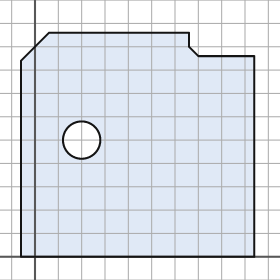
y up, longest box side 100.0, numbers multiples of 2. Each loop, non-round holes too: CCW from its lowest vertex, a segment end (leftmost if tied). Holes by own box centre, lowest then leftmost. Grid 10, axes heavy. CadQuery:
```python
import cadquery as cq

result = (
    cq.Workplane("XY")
    .moveTo(-6.0, 0.0)
    .lineTo(94.0, 0.0)
    .lineTo(94.0, 86.0)
    .lineTo(70.0, 86.0)
    .lineTo(66.0, 90.0)
    .lineTo(66.0, 96.0)
    .lineTo(6.0, 96.0)
    .lineTo(-6.0, 84.0)
    .close()
    .moveTo(20.0, 50.0)
    .circle(8.0)
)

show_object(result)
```